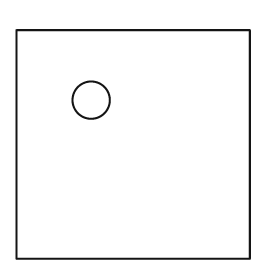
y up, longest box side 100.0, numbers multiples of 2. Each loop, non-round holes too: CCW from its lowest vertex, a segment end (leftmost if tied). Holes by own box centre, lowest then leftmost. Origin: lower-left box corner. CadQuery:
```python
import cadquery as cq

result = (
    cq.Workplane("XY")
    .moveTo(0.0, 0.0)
    .lineTo(100.0, 0.0)
    .lineTo(100.0, 98.0)
    .lineTo(0.0, 98.0)
    .close()
    .moveTo(32.0, 68.0)
    .circle(8.0)
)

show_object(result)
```